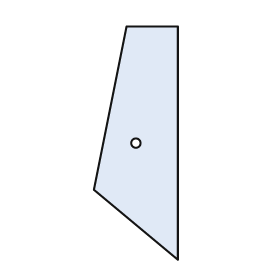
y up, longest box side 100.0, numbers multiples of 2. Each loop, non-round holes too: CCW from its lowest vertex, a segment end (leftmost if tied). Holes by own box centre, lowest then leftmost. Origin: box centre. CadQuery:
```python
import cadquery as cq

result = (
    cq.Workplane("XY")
    .moveTo(18.0, -50.0)
    .lineTo(18.0, 50.0)
    .lineTo(-4.0, 50.0)
    .lineTo(-18.0, -20.0)
    .close()
    .moveTo(0.0, 0.0)
    .circle(2.0)
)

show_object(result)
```